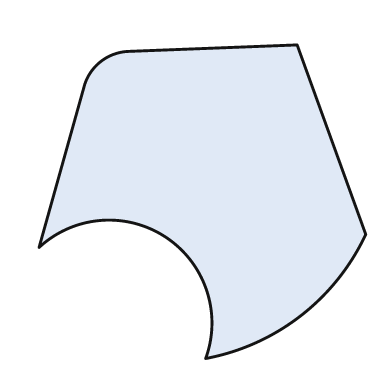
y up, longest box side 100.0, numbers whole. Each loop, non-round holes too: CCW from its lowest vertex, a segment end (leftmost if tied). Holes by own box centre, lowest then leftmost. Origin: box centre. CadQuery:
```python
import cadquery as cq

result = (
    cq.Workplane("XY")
    .moveTo(1.0, -48.0)
    .threePointArc((30.0, -35.0), (50.0, -10.0))
    .lineTo(29.0, 48.0)
    .lineTo(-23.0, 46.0)
    .threePointArc((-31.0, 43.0), (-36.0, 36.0))
    .lineTo(-50.0, -14.0)
    .threePointArc((-11.0, -11.0), (1.0, -48.0))
    .close()
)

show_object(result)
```